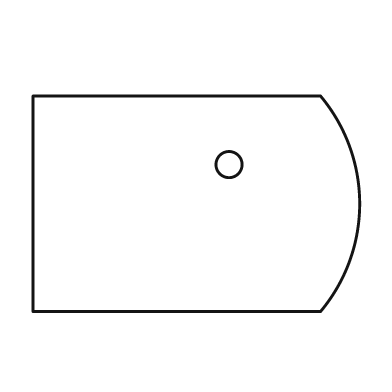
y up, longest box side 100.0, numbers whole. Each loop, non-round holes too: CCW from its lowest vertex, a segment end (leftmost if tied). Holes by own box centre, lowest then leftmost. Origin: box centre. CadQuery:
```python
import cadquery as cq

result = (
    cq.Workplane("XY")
    .moveTo(-50.0, -33.0)
    .lineTo(38.0, -33.0)
    .threePointArc((50.0, 0.0), (38.0, 33.0))
    .lineTo(-50.0, 33.0)
    .close()
    .moveTo(10.0, 12.0)
    .circle(4.0)
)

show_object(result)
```